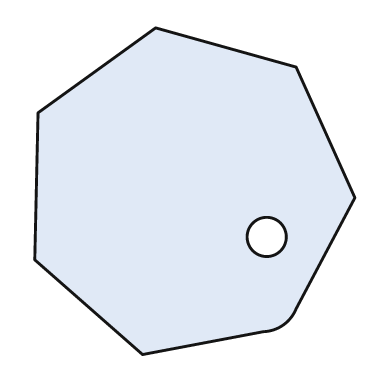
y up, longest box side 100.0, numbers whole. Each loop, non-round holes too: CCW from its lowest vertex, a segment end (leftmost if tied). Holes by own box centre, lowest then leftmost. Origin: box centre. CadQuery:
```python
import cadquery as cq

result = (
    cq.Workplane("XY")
    .moveTo(-16.0, -50.0)
    .lineTo(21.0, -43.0)
    .threePointArc((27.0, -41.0), (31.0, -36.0))
    .lineTo(49.0, -2.0)
    .lineTo(31.0, 38.0)
    .lineTo(-12.0, 50.0)
    .lineTo(-48.0, 24.0)
    .lineTo(-49.0, -21.0)
    .close()
    .moveTo(22.0, -14.0)
    .circle(6.0)
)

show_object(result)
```